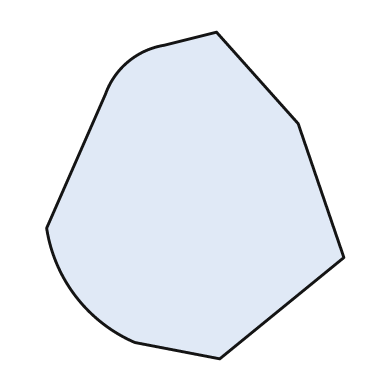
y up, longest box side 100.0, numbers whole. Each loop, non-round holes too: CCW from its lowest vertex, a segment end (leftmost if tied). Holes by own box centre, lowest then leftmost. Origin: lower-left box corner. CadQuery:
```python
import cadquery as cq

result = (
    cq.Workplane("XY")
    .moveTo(53.0, 0.0)
    .lineTo(91.0, 31.0)
    .lineTo(77.0, 72.0)
    .lineTo(52.0, 100.0)
    .lineTo(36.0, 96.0)
    .threePointArc((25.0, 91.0), (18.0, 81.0))
    .lineTo(0.0, 40.0)
    .threePointArc((9.0, 19.0), (27.0, 5.0))
    .close()
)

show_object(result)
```